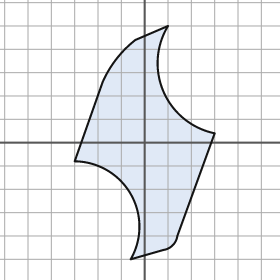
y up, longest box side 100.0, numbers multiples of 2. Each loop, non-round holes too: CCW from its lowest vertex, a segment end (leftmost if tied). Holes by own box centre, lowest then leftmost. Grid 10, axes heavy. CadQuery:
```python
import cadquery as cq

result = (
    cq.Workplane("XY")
    .moveTo(-6.0, -50.0)
    .lineTo(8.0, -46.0)
    .threePointArc((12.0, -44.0), (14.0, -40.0))
    .lineTo(30.0, 4.0)
    .threePointArc((8.0, 22.0), (10.0, 50.0))
    .lineTo(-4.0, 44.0)
    .threePointArc((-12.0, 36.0), (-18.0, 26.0))
    .lineTo(-30.0, -8.0)
    .threePointArc((-6.0, -22.0), (-6.0, -50.0))
    .close()
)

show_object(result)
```